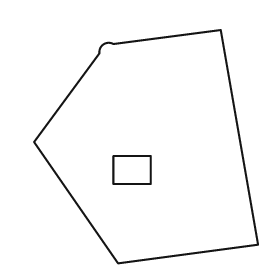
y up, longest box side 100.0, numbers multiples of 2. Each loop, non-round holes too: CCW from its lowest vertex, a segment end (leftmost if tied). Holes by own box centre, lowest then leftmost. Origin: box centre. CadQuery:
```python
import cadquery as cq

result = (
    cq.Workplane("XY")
    .moveTo(-12.0, -50.0)
    .lineTo(48.0, -42.0)
    .lineTo(32.0, 50.0)
    .lineTo(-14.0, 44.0)
    .threePointArc((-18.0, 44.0), (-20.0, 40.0))
    .lineTo(-48.0, 2.0)
    .close()
    .moveTo(-14.0, -16.0)
    .lineTo(2.0, -16.0)
    .lineTo(2.0, -4.0)
    .lineTo(-14.0, -4.0)
    .close()
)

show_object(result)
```